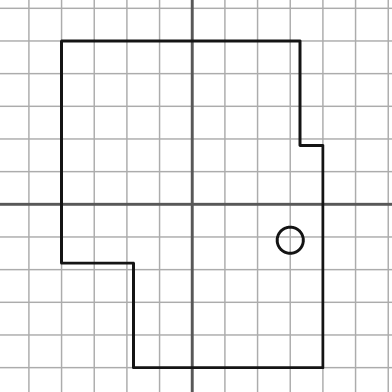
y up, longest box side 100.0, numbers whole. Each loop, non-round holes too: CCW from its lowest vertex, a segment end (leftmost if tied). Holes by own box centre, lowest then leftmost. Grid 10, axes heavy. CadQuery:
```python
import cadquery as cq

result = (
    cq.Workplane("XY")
    .moveTo(-18.0, -50.0)
    .lineTo(40.0, -50.0)
    .lineTo(40.0, 18.0)
    .lineTo(33.0, 18.0)
    .lineTo(33.0, 50.0)
    .lineTo(-40.0, 50.0)
    .lineTo(-40.0, -18.0)
    .lineTo(-18.0, -18.0)
    .close()
    .moveTo(30.0, -11.0)
    .circle(4.0)
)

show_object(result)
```